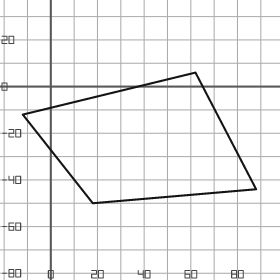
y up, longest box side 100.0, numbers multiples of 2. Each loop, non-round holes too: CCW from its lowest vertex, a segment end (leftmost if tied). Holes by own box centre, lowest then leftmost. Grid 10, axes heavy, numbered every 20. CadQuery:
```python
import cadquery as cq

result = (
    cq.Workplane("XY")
    .moveTo(18.0, -50.0)
    .lineTo(88.0, -44.0)
    .lineTo(62.0, 6.0)
    .lineTo(-12.0, -12.0)
    .close()
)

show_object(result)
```